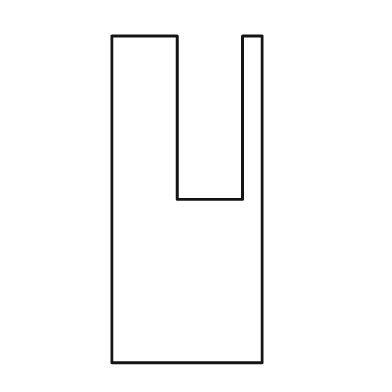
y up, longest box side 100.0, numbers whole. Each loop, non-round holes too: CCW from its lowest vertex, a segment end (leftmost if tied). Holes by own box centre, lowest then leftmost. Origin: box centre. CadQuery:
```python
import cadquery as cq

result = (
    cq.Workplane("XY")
    .moveTo(-23.0, -50.0)
    .lineTo(23.0, -50.0)
    .lineTo(23.0, 50.0)
    .lineTo(17.0, 50.0)
    .lineTo(17.0, 0.0)
    .lineTo(-3.0, 0.0)
    .lineTo(-3.0, 50.0)
    .lineTo(-23.0, 50.0)
    .close()
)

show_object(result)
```